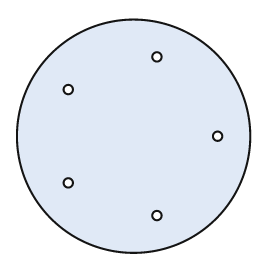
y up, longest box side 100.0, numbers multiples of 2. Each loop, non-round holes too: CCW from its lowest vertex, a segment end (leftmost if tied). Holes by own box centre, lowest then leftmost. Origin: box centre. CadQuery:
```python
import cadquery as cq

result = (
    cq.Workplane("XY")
    .moveTo(0.0, 0.0)
    .circle(50.0)
    .moveTo(10.0, -34.0)
    .circle(2.0)
    .moveTo(-28.0, -20.0)
    .circle(2.0)
    .moveTo(36.0, 0.0)
    .circle(2.0)
    .moveTo(-28.0, 20.0)
    .circle(2.0)
    .moveTo(10.0, 34.0)
    .circle(2.0)
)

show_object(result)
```